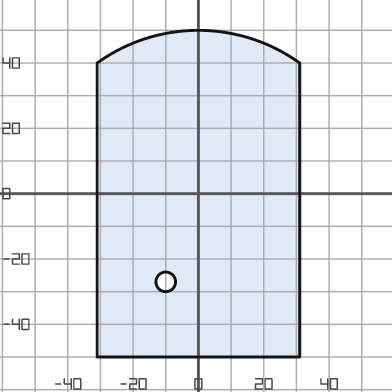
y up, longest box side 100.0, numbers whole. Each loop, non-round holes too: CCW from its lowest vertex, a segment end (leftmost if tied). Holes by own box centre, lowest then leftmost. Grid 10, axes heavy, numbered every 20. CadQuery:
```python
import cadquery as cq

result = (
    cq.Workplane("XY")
    .moveTo(-31.0, -50.0)
    .lineTo(31.0, -50.0)
    .lineTo(31.0, 40.0)
    .threePointArc((0.0, 50.0), (-31.0, 40.0))
    .close()
    .moveTo(-10.0, -27.0)
    .circle(3.0)
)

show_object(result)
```